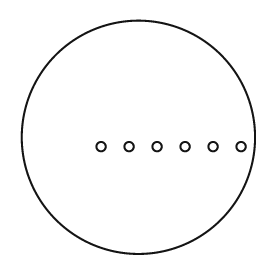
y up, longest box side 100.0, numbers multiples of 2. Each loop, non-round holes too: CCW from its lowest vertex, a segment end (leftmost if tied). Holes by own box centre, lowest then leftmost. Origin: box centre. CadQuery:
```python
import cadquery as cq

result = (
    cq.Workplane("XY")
    .moveTo(0.0, 0.0)
    .circle(50.0)
    .moveTo(-16.0, -4.0)
    .circle(2.0)
    .moveTo(-4.0, -4.0)
    .circle(2.0)
    .moveTo(8.0, -4.0)
    .circle(2.0)
    .moveTo(20.0, -4.0)
    .circle(2.0)
    .moveTo(32.0, -4.0)
    .circle(2.0)
    .moveTo(44.0, -4.0)
    .circle(2.0)
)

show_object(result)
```